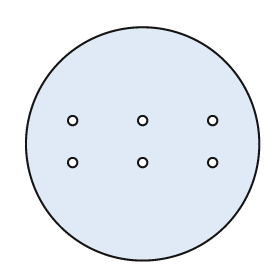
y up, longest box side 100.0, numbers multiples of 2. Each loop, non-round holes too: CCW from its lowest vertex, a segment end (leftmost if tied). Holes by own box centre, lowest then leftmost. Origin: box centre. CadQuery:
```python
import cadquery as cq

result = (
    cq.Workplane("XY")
    .moveTo(0.0, 0.0)
    .circle(50.0)
    .moveTo(-30.0, -8.0)
    .circle(2.0)
    .moveTo(0.0, -8.0)
    .circle(2.0)
    .moveTo(30.0, -8.0)
    .circle(2.0)
    .moveTo(-30.0, 10.0)
    .circle(2.0)
    .moveTo(0.0, 10.0)
    .circle(2.0)
    .moveTo(30.0, 10.0)
    .circle(2.0)
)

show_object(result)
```